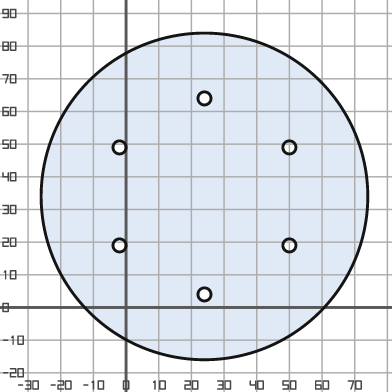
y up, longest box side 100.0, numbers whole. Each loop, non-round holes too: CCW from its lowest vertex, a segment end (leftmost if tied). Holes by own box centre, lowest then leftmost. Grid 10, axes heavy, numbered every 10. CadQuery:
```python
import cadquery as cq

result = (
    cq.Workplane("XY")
    .moveTo(24.0, 34.0)
    .circle(50.0)
    .moveTo(24.0, 4.0)
    .circle(2.0)
    .moveTo(-2.0, 19.0)
    .circle(2.0)
    .moveTo(50.0, 19.0)
    .circle(2.0)
    .moveTo(-2.0, 49.0)
    .circle(2.0)
    .moveTo(50.0, 49.0)
    .circle(2.0)
    .moveTo(24.0, 64.0)
    .circle(2.0)
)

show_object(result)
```